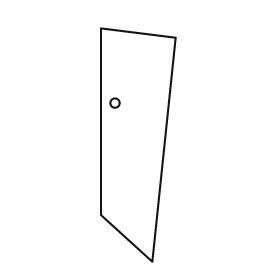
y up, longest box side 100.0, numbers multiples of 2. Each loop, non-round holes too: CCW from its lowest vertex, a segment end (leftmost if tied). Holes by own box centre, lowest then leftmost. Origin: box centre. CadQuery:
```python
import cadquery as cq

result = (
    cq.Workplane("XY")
    .moveTo(6.0, -50.0)
    .lineTo(16.0, 46.0)
    .lineTo(-16.0, 50.0)
    .lineTo(-16.0, -30.0)
    .close()
    .moveTo(-10.0, 18.0)
    .circle(2.0)
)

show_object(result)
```